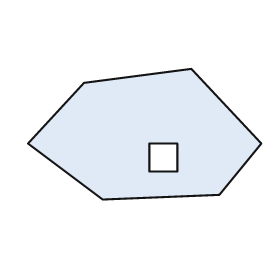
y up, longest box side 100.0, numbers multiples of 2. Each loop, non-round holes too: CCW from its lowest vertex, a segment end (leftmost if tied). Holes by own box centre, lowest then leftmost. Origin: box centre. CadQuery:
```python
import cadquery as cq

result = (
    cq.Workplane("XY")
    .moveTo(-18.0, -28.0)
    .lineTo(32.0, -26.0)
    .lineTo(50.0, -4.0)
    .lineTo(20.0, 28.0)
    .lineTo(-26.0, 22.0)
    .lineTo(-50.0, -4.0)
    .close()
    .moveTo(2.0, -16.0)
    .lineTo(14.0, -16.0)
    .lineTo(14.0, -4.0)
    .lineTo(2.0, -4.0)
    .close()
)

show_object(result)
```